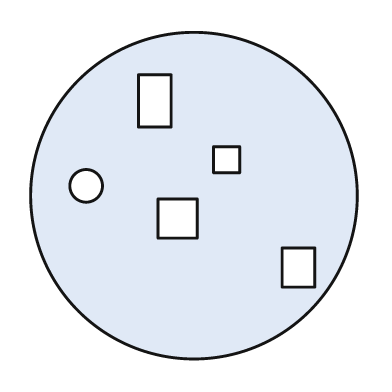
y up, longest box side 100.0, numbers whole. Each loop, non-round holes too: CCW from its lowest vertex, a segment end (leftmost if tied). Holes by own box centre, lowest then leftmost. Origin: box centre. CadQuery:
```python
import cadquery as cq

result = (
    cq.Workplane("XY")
    .moveTo(0.0, 0.0)
    .circle(50.0)
    .moveTo(27.0, -28.0)
    .lineTo(37.0, -28.0)
    .lineTo(37.0, -16.0)
    .lineTo(27.0, -16.0)
    .close()
    .moveTo(-11.0, -13.0)
    .lineTo(1.0, -13.0)
    .lineTo(1.0, -1.0)
    .lineTo(-11.0, -1.0)
    .close()
    .moveTo(-33.0, 3.0)
    .circle(5.0)
    .moveTo(6.0, 7.0)
    .lineTo(14.0, 7.0)
    .lineTo(14.0, 15.0)
    .lineTo(6.0, 15.0)
    .close()
    .moveTo(-17.0, 21.0)
    .lineTo(-7.0, 21.0)
    .lineTo(-7.0, 37.0)
    .lineTo(-17.0, 37.0)
    .close()
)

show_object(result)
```